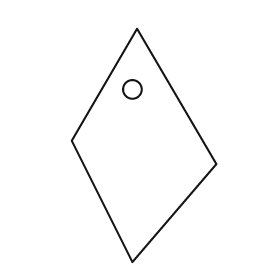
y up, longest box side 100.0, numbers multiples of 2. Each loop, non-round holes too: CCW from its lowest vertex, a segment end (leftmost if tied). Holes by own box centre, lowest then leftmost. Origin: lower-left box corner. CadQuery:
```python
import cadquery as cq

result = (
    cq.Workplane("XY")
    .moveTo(26.0, 0.0)
    .lineTo(62.0, 42.0)
    .lineTo(28.0, 100.0)
    .lineTo(0.0, 52.0)
    .close()
    .moveTo(26.0, 74.0)
    .circle(4.0)
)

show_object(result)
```